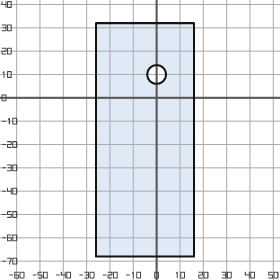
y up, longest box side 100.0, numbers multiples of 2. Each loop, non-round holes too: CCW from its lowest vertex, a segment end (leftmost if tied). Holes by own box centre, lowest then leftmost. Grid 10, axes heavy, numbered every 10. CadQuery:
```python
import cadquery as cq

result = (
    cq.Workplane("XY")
    .moveTo(-26.0, -68.0)
    .lineTo(16.0, -68.0)
    .lineTo(16.0, 32.0)
    .lineTo(-26.0, 32.0)
    .close()
    .moveTo(0.0, 10.0)
    .circle(4.0)
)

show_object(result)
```